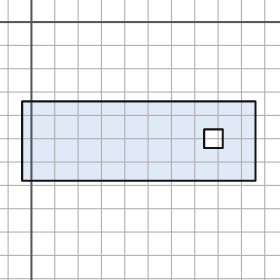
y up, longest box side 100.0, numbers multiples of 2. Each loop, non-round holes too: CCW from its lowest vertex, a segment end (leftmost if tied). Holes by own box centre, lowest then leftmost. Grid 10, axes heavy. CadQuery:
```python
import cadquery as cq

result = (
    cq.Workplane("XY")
    .moveTo(-4.0, -68.0)
    .lineTo(96.0, -68.0)
    .lineTo(96.0, -34.0)
    .lineTo(-4.0, -34.0)
    .close()
    .moveTo(74.0, -54.0)
    .lineTo(82.0, -54.0)
    .lineTo(82.0, -46.0)
    .lineTo(74.0, -46.0)
    .close()
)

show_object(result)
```